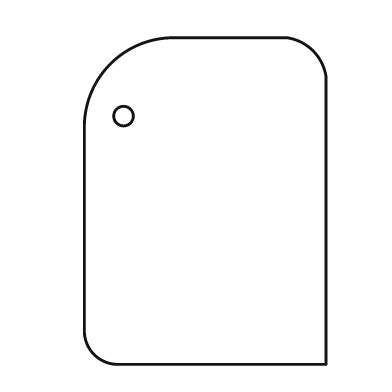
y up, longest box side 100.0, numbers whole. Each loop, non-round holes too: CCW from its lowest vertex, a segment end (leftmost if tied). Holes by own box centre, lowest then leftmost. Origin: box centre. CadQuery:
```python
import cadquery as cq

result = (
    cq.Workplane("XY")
    .moveTo(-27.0, -50.0)
    .lineTo(37.0, -50.0)
    .lineTo(37.0, 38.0)
    .threePointArc((33.0, 46.0), (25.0, 50.0))
    .lineTo(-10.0, 50.0)
    .threePointArc((-29.0, 42.0), (-37.0, 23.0))
    .lineTo(-37.0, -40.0)
    .threePointArc((-34.0, -47.0), (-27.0, -50.0))
    .close()
    .moveTo(-25.0, 26.0)
    .circle(3.0)
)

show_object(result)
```